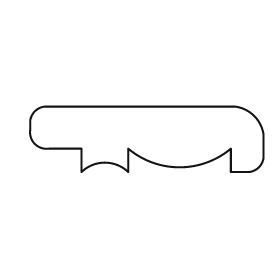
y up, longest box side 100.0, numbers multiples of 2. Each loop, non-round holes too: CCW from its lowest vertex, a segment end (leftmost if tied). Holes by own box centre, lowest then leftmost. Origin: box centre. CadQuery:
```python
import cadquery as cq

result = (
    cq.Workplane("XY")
    .moveTo(-28.0, -14.0)
    .threePointArc((-18.0, -10.0), (-8.0, -14.0))
    .lineTo(-8.0, -4.0)
    .threePointArc((14.0, -12.0), (36.0, -4.0))
    .lineTo(36.0, -14.0)
    .lineTo(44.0, -14.0)
    .threePointArc((48.0, -12.0), (50.0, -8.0))
    .lineTo(50.0, 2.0)
    .threePointArc((46.0, 10.0), (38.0, 14.0))
    .lineTo(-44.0, 14.0)
    .threePointArc((-48.0, 12.0), (-50.0, 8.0))
    .lineTo(-50.0, 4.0)
    .threePointArc((-48.0, -2.0), (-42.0, -4.0))
    .lineTo(-28.0, -4.0)
    .close()
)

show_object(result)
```